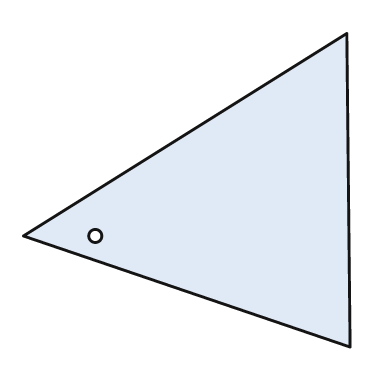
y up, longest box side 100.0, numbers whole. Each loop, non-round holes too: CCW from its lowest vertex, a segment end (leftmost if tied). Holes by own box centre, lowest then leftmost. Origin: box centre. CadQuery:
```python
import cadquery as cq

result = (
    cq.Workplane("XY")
    .moveTo(50.0, -48.0)
    .lineTo(49.0, 48.0)
    .lineTo(-50.0, -14.0)
    .close()
    .moveTo(-28.0, -14.0)
    .circle(2.0)
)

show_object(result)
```